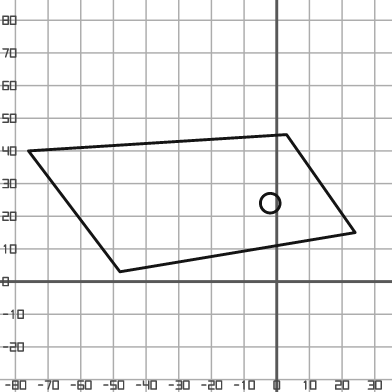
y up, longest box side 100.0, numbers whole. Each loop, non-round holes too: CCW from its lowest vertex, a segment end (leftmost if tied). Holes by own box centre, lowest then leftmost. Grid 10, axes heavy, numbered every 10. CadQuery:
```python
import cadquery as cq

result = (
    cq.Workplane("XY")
    .moveTo(-48.0, 3.0)
    .lineTo(24.0, 15.0)
    .lineTo(3.0, 45.0)
    .lineTo(-76.0, 40.0)
    .close()
    .moveTo(-2.0, 24.0)
    .circle(3.0)
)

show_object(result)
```